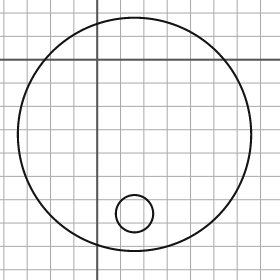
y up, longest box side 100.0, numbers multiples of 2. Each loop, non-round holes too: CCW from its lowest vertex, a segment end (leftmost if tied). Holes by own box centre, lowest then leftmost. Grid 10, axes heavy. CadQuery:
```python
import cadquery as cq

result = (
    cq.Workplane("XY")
    .moveTo(16.0, -32.0)
    .circle(50.0)
    .moveTo(16.0, -66.0)
    .circle(8.0)
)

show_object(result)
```